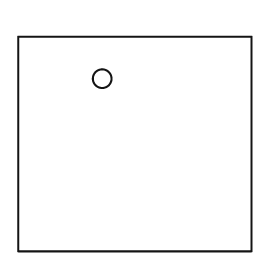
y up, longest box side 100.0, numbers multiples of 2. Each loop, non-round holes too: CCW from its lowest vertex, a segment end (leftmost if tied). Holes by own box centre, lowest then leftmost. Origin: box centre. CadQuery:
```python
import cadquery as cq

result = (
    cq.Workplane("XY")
    .moveTo(-50.0, -46.0)
    .lineTo(50.0, -46.0)
    .lineTo(50.0, 46.0)
    .lineTo(-50.0, 46.0)
    .close()
    .moveTo(-14.0, 28.0)
    .circle(4.0)
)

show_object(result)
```